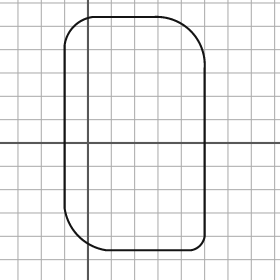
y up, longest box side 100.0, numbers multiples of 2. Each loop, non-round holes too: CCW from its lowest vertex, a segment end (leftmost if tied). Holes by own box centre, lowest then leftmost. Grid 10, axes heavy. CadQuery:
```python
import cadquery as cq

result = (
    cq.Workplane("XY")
    .moveTo(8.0, -46.0)
    .lineTo(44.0, -46.0)
    .threePointArc((48.0, -44.0), (50.0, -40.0))
    .lineTo(50.0, 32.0)
    .threePointArc((44.0, 48.0), (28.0, 54.0))
    .lineTo(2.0, 54.0)
    .threePointArc((-6.0, 50.0), (-10.0, 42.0))
    .lineTo(-10.0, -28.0)
    .threePointArc((-4.0, -40.0), (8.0, -46.0))
    .close()
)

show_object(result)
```